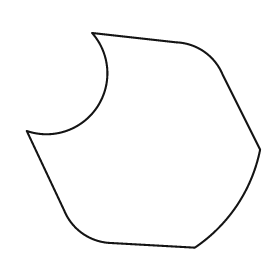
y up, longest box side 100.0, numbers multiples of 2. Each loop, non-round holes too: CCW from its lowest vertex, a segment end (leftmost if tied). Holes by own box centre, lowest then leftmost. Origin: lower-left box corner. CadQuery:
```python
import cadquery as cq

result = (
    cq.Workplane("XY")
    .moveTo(72.0, 0.0)
    .threePointArc((90.0, 18.0), (100.0, 42.0))
    .lineTo(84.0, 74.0)
    .threePointArc((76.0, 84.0), (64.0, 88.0))
    .lineTo(28.0, 92.0)
    .threePointArc((30.0, 60.0), (0.0, 50.0))
    .lineTo(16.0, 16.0)
    .threePointArc((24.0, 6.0), (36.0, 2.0))
    .close()
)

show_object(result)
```